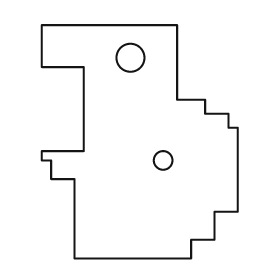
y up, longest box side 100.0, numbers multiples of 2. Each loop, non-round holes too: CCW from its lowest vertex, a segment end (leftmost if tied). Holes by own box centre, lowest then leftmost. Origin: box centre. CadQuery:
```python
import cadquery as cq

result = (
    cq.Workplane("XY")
    .moveTo(-28.0, -50.0)
    .lineTo(22.0, -50.0)
    .lineTo(22.0, -42.0)
    .lineTo(32.0, -42.0)
    .lineTo(32.0, -30.0)
    .lineTo(42.0, -30.0)
    .lineTo(42.0, 6.0)
    .lineTo(38.0, 6.0)
    .lineTo(38.0, 12.0)
    .lineTo(28.0, 12.0)
    .lineTo(28.0, 18.0)
    .lineTo(16.0, 18.0)
    .lineTo(16.0, 50.0)
    .lineTo(-42.0, 50.0)
    .lineTo(-42.0, 32.0)
    .lineTo(-24.0, 32.0)
    .lineTo(-24.0, -4.0)
    .lineTo(-42.0, -4.0)
    .lineTo(-42.0, -8.0)
    .lineTo(-38.0, -8.0)
    .lineTo(-38.0, -16.0)
    .lineTo(-28.0, -16.0)
    .close()
    .moveTo(10.0, -8.0)
    .circle(4.0)
    .moveTo(-4.0, 36.0)
    .circle(6.0)
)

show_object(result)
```